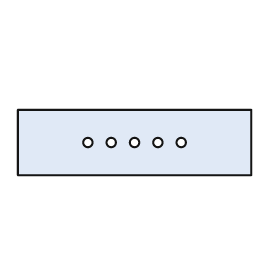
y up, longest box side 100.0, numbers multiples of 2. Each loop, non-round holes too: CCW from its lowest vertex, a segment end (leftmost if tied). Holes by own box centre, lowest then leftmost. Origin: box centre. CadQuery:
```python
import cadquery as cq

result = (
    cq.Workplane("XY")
    .moveTo(-50.0, -14.0)
    .lineTo(50.0, -14.0)
    .lineTo(50.0, 14.0)
    .lineTo(-50.0, 14.0)
    .close()
    .moveTo(-20.0, 0.0)
    .circle(2.0)
    .moveTo(-10.0, 0.0)
    .circle(2.0)
    .moveTo(0.0, 0.0)
    .circle(2.0)
    .moveTo(10.0, 0.0)
    .circle(2.0)
    .moveTo(20.0, 0.0)
    .circle(2.0)
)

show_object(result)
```